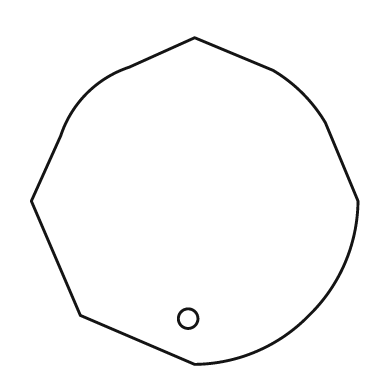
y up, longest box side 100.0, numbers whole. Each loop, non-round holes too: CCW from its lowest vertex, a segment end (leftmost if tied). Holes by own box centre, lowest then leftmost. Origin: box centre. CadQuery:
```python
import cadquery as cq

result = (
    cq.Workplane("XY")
    .moveTo(0.0, -50.0)
    .threePointArc((19.0, -46.0), (35.0, -35.0))
    .threePointArc((46.0, -19.0), (50.0, 0.0))
    .lineTo(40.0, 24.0)
    .threePointArc((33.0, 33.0), (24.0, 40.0))
    .lineTo(0.0, 50.0)
    .lineTo(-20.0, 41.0)
    .threePointArc((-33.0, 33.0), (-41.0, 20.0))
    .lineTo(-50.0, 0.0)
    .lineTo(-35.0, -35.0)
    .close()
    .moveTo(-2.0, -36.0)
    .circle(3.0)
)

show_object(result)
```